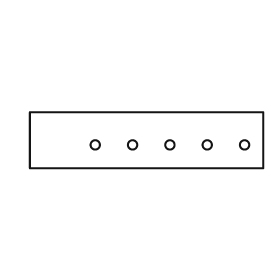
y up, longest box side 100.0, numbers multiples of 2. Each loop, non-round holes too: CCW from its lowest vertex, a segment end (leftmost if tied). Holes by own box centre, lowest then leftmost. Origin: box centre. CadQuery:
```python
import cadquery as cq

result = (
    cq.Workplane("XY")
    .moveTo(-50.0, -12.0)
    .lineTo(50.0, -12.0)
    .lineTo(50.0, 12.0)
    .lineTo(-50.0, 12.0)
    .close()
    .moveTo(-22.0, -2.0)
    .circle(2.0)
    .moveTo(-6.0, -2.0)
    .circle(2.0)
    .moveTo(10.0, -2.0)
    .circle(2.0)
    .moveTo(26.0, -2.0)
    .circle(2.0)
    .moveTo(42.0, -2.0)
    .circle(2.0)
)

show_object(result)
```